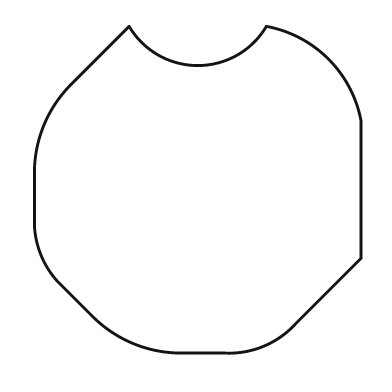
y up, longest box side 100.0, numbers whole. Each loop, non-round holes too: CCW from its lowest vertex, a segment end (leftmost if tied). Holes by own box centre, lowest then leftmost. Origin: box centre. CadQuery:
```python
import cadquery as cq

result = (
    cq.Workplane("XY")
    .moveTo(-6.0, -50.0)
    .lineTo(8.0, -50.0)
    .threePointArc((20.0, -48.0), (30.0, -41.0))
    .lineTo(50.0, -21.0)
    .lineTo(50.0, 21.0)
    .threePointArc((40.0, 40.0), (21.0, 50.0))
    .threePointArc((0.0, 38.0), (-21.0, 50.0))
    .lineTo(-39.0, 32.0)
    .threePointArc((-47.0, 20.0), (-50.0, 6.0))
    .lineTo(-50.0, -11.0)
    .threePointArc((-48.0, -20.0), (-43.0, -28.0))
    .lineTo(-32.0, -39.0)
    .threePointArc((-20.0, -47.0), (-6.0, -50.0))
    .close()
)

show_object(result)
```